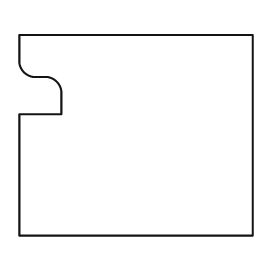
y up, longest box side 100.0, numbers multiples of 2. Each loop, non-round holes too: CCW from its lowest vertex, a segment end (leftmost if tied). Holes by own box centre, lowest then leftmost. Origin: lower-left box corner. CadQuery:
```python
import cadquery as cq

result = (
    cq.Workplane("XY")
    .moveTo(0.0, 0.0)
    .lineTo(100.0, 0.0)
    .lineTo(100.0, 86.0)
    .lineTo(0.0, 86.0)
    .lineTo(0.0, 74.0)
    .threePointArc((2.0, 70.0), (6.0, 68.0))
    .lineTo(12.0, 68.0)
    .threePointArc((16.0, 66.0), (18.0, 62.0))
    .lineTo(18.0, 52.0)
    .lineTo(0.0, 52.0)
    .close()
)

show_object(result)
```